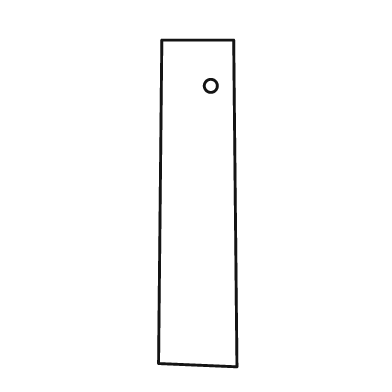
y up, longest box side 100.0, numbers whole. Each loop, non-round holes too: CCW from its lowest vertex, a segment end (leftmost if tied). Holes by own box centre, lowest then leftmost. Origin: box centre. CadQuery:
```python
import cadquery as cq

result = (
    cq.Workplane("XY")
    .moveTo(12.0, -50.0)
    .lineTo(11.0, 50.0)
    .lineTo(-11.0, 50.0)
    .lineTo(-12.0, -49.0)
    .close()
    .moveTo(4.0, 36.0)
    .circle(2.0)
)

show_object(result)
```